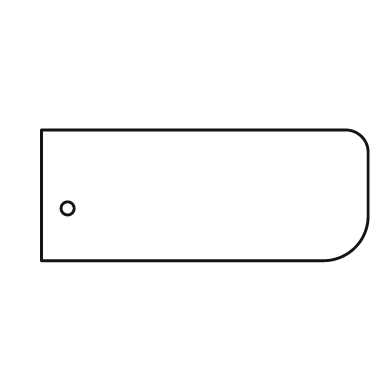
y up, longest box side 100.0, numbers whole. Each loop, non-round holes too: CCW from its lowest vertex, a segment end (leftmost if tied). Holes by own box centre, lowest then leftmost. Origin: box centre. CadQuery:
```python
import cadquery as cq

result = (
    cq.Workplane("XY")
    .moveTo(-50.0, -20.0)
    .lineTo(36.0, -20.0)
    .threePointArc((46.0, -16.0), (50.0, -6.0))
    .lineTo(50.0, 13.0)
    .threePointArc((48.0, 18.0), (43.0, 20.0))
    .lineTo(-50.0, 20.0)
    .close()
    .moveTo(-42.0, -4.0)
    .circle(2.0)
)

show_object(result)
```